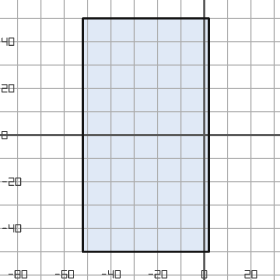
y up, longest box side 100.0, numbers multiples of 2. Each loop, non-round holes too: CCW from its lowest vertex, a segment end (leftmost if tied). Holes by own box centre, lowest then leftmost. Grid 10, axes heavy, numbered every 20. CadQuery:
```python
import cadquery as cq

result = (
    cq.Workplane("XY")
    .moveTo(-52.0, -50.0)
    .lineTo(2.0, -50.0)
    .lineTo(2.0, 50.0)
    .lineTo(-52.0, 50.0)
    .close()
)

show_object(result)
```